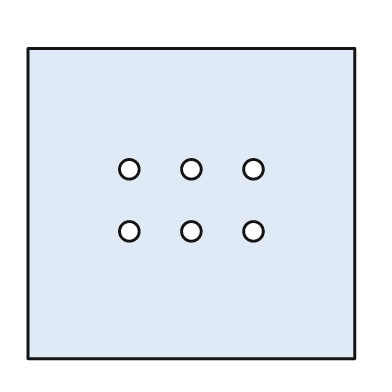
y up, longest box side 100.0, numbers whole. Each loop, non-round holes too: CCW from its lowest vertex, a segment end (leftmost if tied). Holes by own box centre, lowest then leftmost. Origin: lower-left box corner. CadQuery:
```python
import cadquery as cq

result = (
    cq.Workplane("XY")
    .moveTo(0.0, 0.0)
    .lineTo(100.0, 0.0)
    .lineTo(100.0, 95.0)
    .lineTo(0.0, 95.0)
    .close()
    .moveTo(31.0, 39.0)
    .circle(3.0)
    .moveTo(50.0, 39.0)
    .circle(3.0)
    .moveTo(69.0, 39.0)
    .circle(3.0)
    .moveTo(31.0, 58.0)
    .circle(3.0)
    .moveTo(50.0, 58.0)
    .circle(3.0)
    .moveTo(69.0, 58.0)
    .circle(3.0)
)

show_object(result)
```